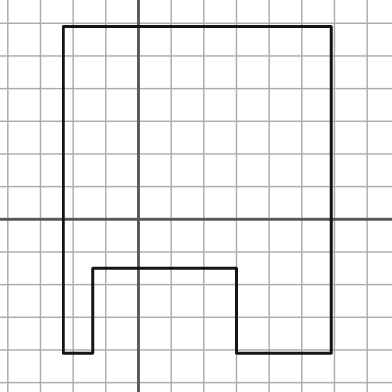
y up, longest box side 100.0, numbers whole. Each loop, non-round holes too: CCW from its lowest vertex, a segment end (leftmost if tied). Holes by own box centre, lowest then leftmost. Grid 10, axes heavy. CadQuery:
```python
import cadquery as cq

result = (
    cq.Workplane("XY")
    .moveTo(-23.0, -41.0)
    .lineTo(-14.0, -41.0)
    .lineTo(-14.0, -15.0)
    .lineTo(30.0, -15.0)
    .lineTo(30.0, -41.0)
    .lineTo(59.0, -41.0)
    .lineTo(59.0, 59.0)
    .lineTo(-23.0, 59.0)
    .close()
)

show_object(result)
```